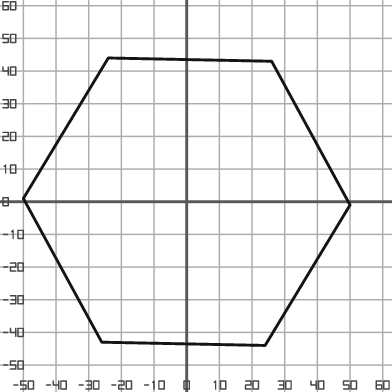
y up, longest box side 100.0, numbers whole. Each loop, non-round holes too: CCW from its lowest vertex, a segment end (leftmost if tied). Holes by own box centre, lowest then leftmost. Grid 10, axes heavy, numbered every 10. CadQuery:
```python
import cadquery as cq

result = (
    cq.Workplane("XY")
    .moveTo(24.0, -44.0)
    .lineTo(50.0, -1.0)
    .lineTo(26.0, 43.0)
    .lineTo(-24.0, 44.0)
    .lineTo(-50.0, 1.0)
    .lineTo(-26.0, -43.0)
    .close()
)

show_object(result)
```